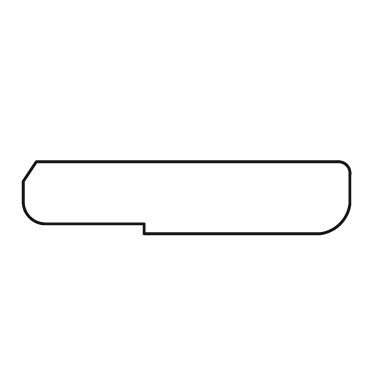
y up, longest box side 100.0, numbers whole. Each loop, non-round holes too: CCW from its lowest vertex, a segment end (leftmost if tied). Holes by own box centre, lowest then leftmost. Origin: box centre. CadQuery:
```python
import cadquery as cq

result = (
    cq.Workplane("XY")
    .moveTo(-13.0, -11.0)
    .lineTo(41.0, -11.0)
    .threePointArc((47.0, -8.0), (50.0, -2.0))
    .lineTo(50.0, 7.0)
    .threePointArc((49.0, 10.0), (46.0, 11.0))
    .lineTo(-46.0, 11.0)
    .lineTo(-50.0, 5.0)
    .lineTo(-50.0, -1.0)
    .threePointArc((-48.0, -6.0), (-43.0, -8.0))
    .lineTo(-13.0, -8.0)
    .close()
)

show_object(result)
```